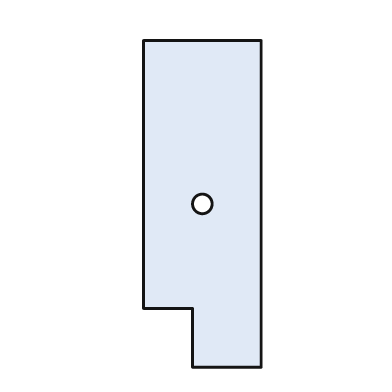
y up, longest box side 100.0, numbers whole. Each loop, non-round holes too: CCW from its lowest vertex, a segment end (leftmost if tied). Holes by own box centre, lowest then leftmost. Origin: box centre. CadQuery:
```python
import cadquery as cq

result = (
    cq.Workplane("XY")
    .moveTo(-3.0, -50.0)
    .lineTo(18.0, -50.0)
    .lineTo(18.0, 50.0)
    .lineTo(-18.0, 50.0)
    .lineTo(-18.0, -32.0)
    .lineTo(-3.0, -32.0)
    .close()
    .moveTo(0.0, 0.0)
    .circle(3.0)
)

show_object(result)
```